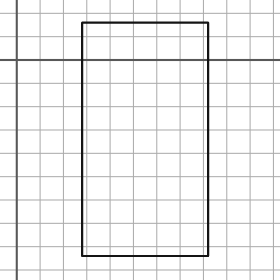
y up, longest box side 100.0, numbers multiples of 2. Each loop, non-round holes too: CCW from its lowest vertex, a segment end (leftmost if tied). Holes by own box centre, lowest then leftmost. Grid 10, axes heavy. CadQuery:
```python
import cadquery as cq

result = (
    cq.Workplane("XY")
    .moveTo(28.0, -84.0)
    .lineTo(82.0, -84.0)
    .lineTo(82.0, 16.0)
    .lineTo(28.0, 16.0)
    .close()
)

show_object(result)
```